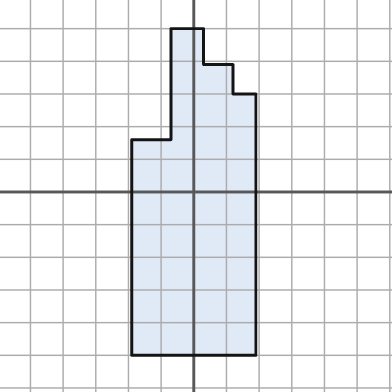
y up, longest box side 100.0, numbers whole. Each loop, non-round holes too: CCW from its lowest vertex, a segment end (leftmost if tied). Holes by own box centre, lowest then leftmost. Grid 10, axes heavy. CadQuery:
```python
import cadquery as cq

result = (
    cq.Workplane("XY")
    .moveTo(-19.0, -50.0)
    .lineTo(19.0, -50.0)
    .lineTo(19.0, 30.0)
    .lineTo(12.0, 30.0)
    .lineTo(12.0, 39.0)
    .lineTo(3.0, 39.0)
    .lineTo(3.0, 50.0)
    .lineTo(-7.0, 50.0)
    .lineTo(-7.0, 16.0)
    .lineTo(-19.0, 16.0)
    .close()
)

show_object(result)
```